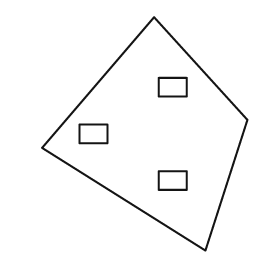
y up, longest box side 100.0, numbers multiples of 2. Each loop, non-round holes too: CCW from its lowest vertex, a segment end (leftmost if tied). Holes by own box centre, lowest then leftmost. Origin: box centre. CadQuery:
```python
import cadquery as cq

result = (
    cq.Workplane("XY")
    .moveTo(26.0, -50.0)
    .lineTo(44.0, 6.0)
    .lineTo(4.0, 50.0)
    .lineTo(-44.0, -6.0)
    .close()
    .moveTo(6.0, -24.0)
    .lineTo(18.0, -24.0)
    .lineTo(18.0, -16.0)
    .lineTo(6.0, -16.0)
    .close()
    .moveTo(-28.0, -4.0)
    .lineTo(-16.0, -4.0)
    .lineTo(-16.0, 4.0)
    .lineTo(-28.0, 4.0)
    .close()
    .moveTo(6.0, 16.0)
    .lineTo(18.0, 16.0)
    .lineTo(18.0, 24.0)
    .lineTo(6.0, 24.0)
    .close()
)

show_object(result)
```